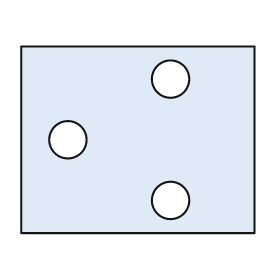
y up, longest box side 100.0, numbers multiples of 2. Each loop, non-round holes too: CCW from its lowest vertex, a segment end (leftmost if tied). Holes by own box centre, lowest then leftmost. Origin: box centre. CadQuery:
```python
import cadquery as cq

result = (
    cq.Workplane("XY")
    .moveTo(-50.0, -40.0)
    .lineTo(50.0, -40.0)
    .lineTo(50.0, 40.0)
    .lineTo(-50.0, 40.0)
    .close()
    .moveTo(14.0, -26.0)
    .circle(8.0)
    .moveTo(-30.0, 0.0)
    .circle(8.0)
    .moveTo(14.0, 26.0)
    .circle(8.0)
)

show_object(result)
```